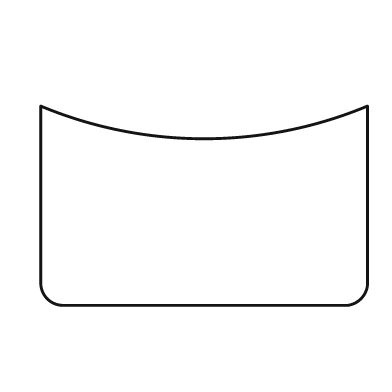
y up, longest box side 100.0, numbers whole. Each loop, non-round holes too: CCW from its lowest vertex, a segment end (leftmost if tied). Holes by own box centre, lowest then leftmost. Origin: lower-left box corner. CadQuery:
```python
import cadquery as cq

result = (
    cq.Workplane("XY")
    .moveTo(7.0, 0.0)
    .lineTo(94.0, 0.0)
    .threePointArc((98.0, 2.0), (100.0, 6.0))
    .lineTo(100.0, 61.0)
    .threePointArc((50.0, 51.0), (0.0, 61.0))
    .lineTo(0.0, 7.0)
    .threePointArc((2.0, 2.0), (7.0, 0.0))
    .close()
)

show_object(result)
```